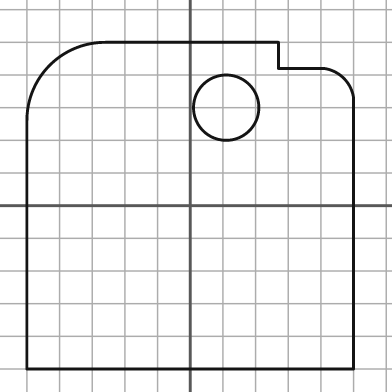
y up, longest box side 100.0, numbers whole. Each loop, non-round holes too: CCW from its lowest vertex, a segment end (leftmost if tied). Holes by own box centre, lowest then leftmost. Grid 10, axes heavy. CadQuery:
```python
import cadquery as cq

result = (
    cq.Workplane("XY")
    .moveTo(-50.0, -50.0)
    .lineTo(50.0, -50.0)
    .lineTo(50.0, 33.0)
    .threePointArc((47.0, 39.0), (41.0, 42.0))
    .lineTo(27.0, 42.0)
    .lineTo(27.0, 50.0)
    .lineTo(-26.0, 50.0)
    .threePointArc((-43.0, 43.0), (-50.0, 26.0))
    .close()
    .moveTo(11.0, 30.0)
    .circle(10.0)
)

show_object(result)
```